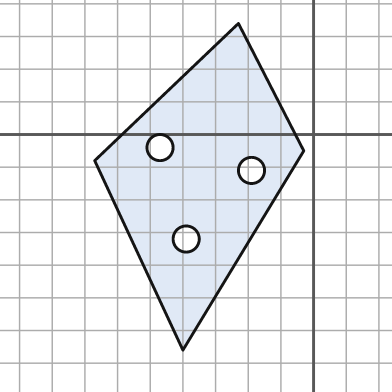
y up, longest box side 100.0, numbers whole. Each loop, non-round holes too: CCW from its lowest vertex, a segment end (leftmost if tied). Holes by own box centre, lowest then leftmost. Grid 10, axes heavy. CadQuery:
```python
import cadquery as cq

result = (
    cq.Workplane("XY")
    .moveTo(-40.0, -66.0)
    .lineTo(-3.0, -5.0)
    .lineTo(-23.0, 34.0)
    .lineTo(-67.0, -8.0)
    .close()
    .moveTo(-39.0, -32.0)
    .circle(4.0)
    .moveTo(-19.0, -11.0)
    .circle(4.0)
    .moveTo(-47.0, -4.0)
    .circle(4.0)
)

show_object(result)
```